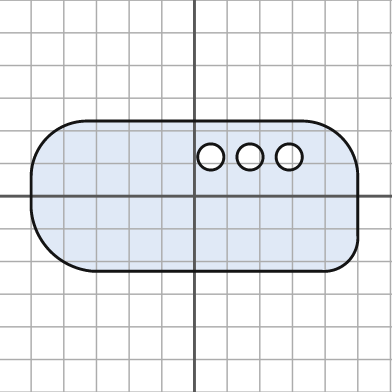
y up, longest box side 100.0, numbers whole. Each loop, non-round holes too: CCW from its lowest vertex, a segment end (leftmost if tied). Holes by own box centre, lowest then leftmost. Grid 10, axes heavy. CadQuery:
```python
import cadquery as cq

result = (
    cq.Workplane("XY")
    .moveTo(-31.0, -23.0)
    .lineTo(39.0, -23.0)
    .threePointArc((47.0, -20.0), (50.0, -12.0))
    .lineTo(50.0, 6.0)
    .threePointArc((45.0, 18.0), (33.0, 23.0))
    .lineTo(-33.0, 23.0)
    .threePointArc((-45.0, 18.0), (-50.0, 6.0))
    .lineTo(-50.0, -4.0)
    .threePointArc((-44.0, -17.0), (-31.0, -23.0))
    .close()
    .moveTo(5.0, 12.0)
    .circle(4.0)
    .moveTo(17.0, 12.0)
    .circle(4.0)
    .moveTo(29.0, 12.0)
    .circle(4.0)
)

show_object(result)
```